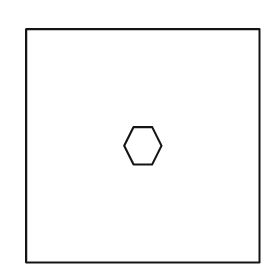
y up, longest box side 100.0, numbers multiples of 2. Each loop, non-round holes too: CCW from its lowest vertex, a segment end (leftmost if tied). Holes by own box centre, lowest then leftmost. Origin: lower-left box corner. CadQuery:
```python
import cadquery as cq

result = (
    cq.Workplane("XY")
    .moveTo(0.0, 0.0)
    .lineTo(100.0, 0.0)
    .lineTo(100.0, 100.0)
    .lineTo(0.0, 100.0)
    .close()
    .moveTo(46.0, 42.0)
    .lineTo(54.0, 42.0)
    .lineTo(58.0, 50.0)
    .lineTo(54.0, 58.0)
    .lineTo(46.0, 58.0)
    .lineTo(42.0, 50.0)
    .close()
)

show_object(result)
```